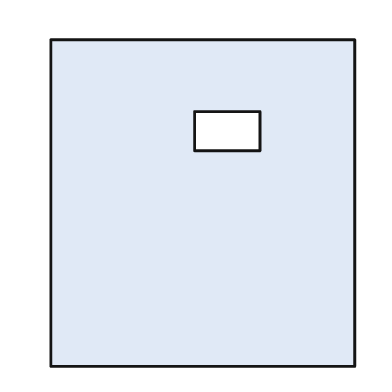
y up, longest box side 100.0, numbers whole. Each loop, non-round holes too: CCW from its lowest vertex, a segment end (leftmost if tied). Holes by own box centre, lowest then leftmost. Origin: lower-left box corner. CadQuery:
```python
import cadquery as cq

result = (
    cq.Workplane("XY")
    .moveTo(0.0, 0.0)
    .lineTo(93.0, 0.0)
    .lineTo(93.0, 100.0)
    .lineTo(0.0, 100.0)
    .close()
    .moveTo(44.0, 66.0)
    .lineTo(64.0, 66.0)
    .lineTo(64.0, 78.0)
    .lineTo(44.0, 78.0)
    .close()
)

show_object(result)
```